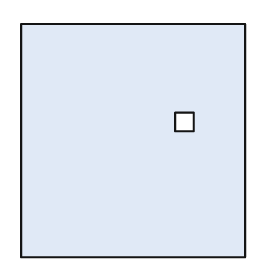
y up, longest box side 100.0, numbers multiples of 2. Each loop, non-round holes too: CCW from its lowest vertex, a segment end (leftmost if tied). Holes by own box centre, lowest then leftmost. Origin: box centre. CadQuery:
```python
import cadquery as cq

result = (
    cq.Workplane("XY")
    .moveTo(-48.0, -50.0)
    .lineTo(48.0, -50.0)
    .lineTo(48.0, 50.0)
    .lineTo(-48.0, 50.0)
    .close()
    .moveTo(18.0, 4.0)
    .lineTo(26.0, 4.0)
    .lineTo(26.0, 12.0)
    .lineTo(18.0, 12.0)
    .close()
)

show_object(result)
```